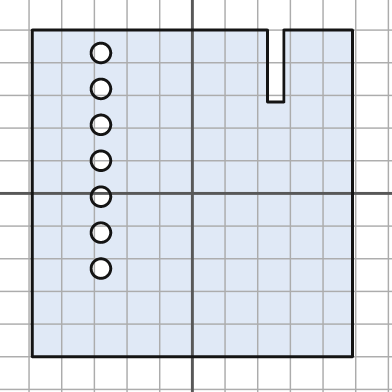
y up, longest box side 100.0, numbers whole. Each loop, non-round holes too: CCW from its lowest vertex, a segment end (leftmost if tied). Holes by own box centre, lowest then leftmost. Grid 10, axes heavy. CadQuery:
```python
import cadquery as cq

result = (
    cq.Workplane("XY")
    .moveTo(-49.0, -50.0)
    .lineTo(49.0, -50.0)
    .lineTo(49.0, 50.0)
    .lineTo(28.0, 50.0)
    .lineTo(28.0, 28.0)
    .lineTo(23.0, 28.0)
    .lineTo(23.0, 50.0)
    .lineTo(-49.0, 50.0)
    .close()
    .moveTo(-28.0, -23.0)
    .circle(3.0)
    .moveTo(-28.0, -12.0)
    .circle(3.0)
    .moveTo(-28.0, -1.0)
    .circle(3.0)
    .moveTo(-28.0, 10.0)
    .circle(3.0)
    .moveTo(-28.0, 21.0)
    .circle(3.0)
    .moveTo(-28.0, 32.0)
    .circle(3.0)
    .moveTo(-28.0, 43.0)
    .circle(3.0)
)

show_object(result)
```